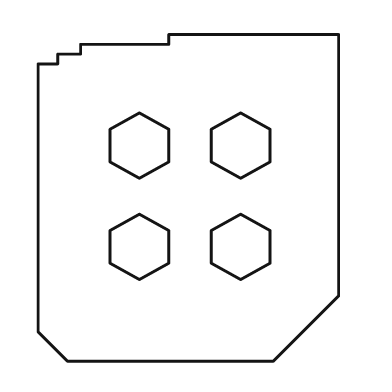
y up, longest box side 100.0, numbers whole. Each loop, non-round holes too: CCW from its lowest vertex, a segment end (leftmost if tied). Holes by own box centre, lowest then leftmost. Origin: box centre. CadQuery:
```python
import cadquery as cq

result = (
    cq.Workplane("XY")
    .moveTo(-37.0, -50.0)
    .lineTo(26.0, -50.0)
    .lineTo(46.0, -30.0)
    .lineTo(46.0, 50.0)
    .lineTo(-6.0, 50.0)
    .lineTo(-6.0, 47.0)
    .lineTo(-33.0, 47.0)
    .lineTo(-33.0, 44.0)
    .lineTo(-40.0, 44.0)
    .lineTo(-40.0, 41.0)
    .lineTo(-46.0, 41.0)
    .lineTo(-46.0, -41.0)
    .close()
    .moveTo(-15.0, -25.0)
    .lineTo(-6.0, -20.0)
    .lineTo(-6.0, -10.0)
    .lineTo(-15.0, -5.0)
    .lineTo(-24.0, -10.0)
    .lineTo(-24.0, -20.0)
    .close()
    .moveTo(16.0, -25.0)
    .lineTo(25.0, -20.0)
    .lineTo(25.0, -10.0)
    .lineTo(16.0, -5.0)
    .lineTo(7.0, -10.0)
    .lineTo(7.0, -20.0)
    .close()
    .moveTo(-15.0, 6.0)
    .lineTo(-6.0, 11.0)
    .lineTo(-6.0, 21.0)
    .lineTo(-15.0, 26.0)
    .lineTo(-24.0, 21.0)
    .lineTo(-24.0, 11.0)
    .close()
    .moveTo(16.0, 6.0)
    .lineTo(25.0, 11.0)
    .lineTo(25.0, 21.0)
    .lineTo(16.0, 26.0)
    .lineTo(7.0, 21.0)
    .lineTo(7.0, 11.0)
    .close()
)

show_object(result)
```